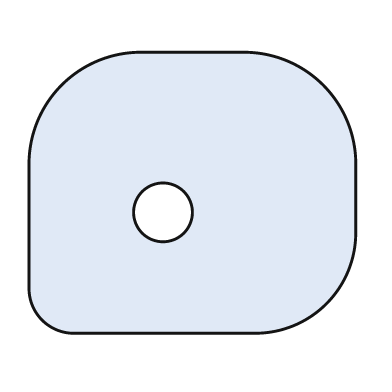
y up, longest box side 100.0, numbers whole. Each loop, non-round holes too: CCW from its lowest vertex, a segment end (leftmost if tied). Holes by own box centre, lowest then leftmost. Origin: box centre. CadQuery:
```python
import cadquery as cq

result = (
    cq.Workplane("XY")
    .moveTo(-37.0, -43.0)
    .lineTo(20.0, -43.0)
    .threePointArc((41.0, -34.0), (50.0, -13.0))
    .lineTo(50.0, 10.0)
    .threePointArc((40.0, 33.0), (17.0, 43.0))
    .lineTo(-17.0, 43.0)
    .threePointArc((-40.0, 33.0), (-50.0, 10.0))
    .lineTo(-50.0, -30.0)
    .threePointArc((-46.0, -39.0), (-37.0, -43.0))
    .close()
    .moveTo(-9.0, -6.0)
    .circle(9.0)
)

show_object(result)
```